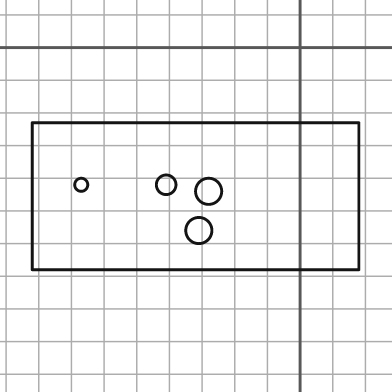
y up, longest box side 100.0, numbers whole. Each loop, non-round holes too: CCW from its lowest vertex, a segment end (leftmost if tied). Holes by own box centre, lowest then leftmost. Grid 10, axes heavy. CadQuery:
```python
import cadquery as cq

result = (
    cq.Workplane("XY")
    .moveTo(-82.0, -68.0)
    .lineTo(18.0, -68.0)
    .lineTo(18.0, -23.0)
    .lineTo(-82.0, -23.0)
    .close()
    .moveTo(-31.0, -56.0)
    .circle(4.0)
    .moveTo(-28.0, -44.0)
    .circle(4.0)
    .moveTo(-67.0, -42.0)
    .circle(2.0)
    .moveTo(-41.0, -42.0)
    .circle(3.0)
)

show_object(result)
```